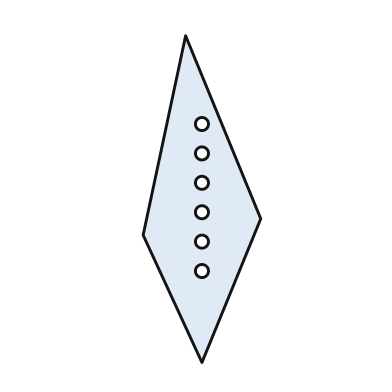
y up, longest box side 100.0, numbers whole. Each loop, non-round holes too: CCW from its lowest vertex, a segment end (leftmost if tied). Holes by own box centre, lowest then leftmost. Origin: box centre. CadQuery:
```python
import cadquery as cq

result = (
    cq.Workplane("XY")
    .moveTo(0.0, -50.0)
    .lineTo(18.0, -6.0)
    .lineTo(-5.0, 50.0)
    .lineTo(-18.0, -11.0)
    .close()
    .moveTo(0.0, -22.0)
    .circle(2.0)
    .moveTo(0.0, -13.0)
    .circle(2.0)
    .moveTo(0.0, -4.0)
    .circle(2.0)
    .moveTo(0.0, 5.0)
    .circle(2.0)
    .moveTo(0.0, 14.0)
    .circle(2.0)
    .moveTo(0.0, 23.0)
    .circle(2.0)
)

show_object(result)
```